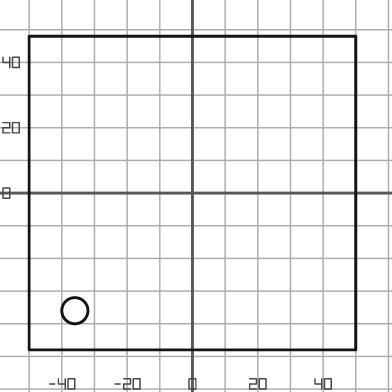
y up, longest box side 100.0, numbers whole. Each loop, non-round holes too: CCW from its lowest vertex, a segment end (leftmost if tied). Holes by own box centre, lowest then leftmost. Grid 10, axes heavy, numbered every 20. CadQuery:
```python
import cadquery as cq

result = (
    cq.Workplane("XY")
    .moveTo(-50.0, -48.0)
    .lineTo(50.0, -48.0)
    .lineTo(50.0, 48.0)
    .lineTo(-50.0, 48.0)
    .close()
    .moveTo(-36.0, -36.0)
    .circle(4.0)
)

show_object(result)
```